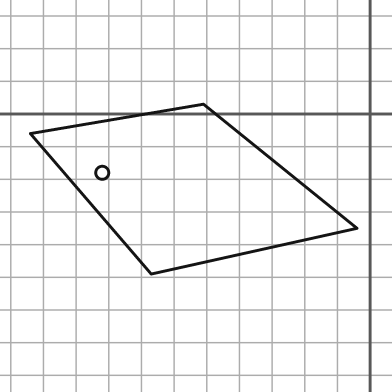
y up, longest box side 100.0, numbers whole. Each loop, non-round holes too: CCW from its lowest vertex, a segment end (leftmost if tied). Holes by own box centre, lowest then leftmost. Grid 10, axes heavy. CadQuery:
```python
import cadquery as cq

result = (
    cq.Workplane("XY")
    .moveTo(-67.0, -49.0)
    .lineTo(-4.0, -35.0)
    .lineTo(-51.0, 3.0)
    .lineTo(-104.0, -6.0)
    .close()
    .moveTo(-82.0, -18.0)
    .circle(2.0)
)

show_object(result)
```